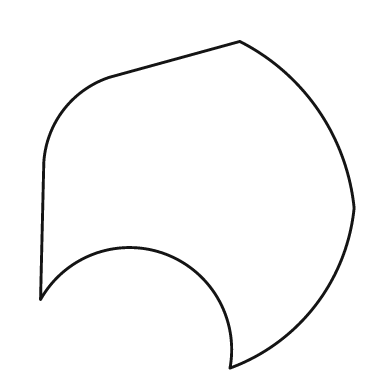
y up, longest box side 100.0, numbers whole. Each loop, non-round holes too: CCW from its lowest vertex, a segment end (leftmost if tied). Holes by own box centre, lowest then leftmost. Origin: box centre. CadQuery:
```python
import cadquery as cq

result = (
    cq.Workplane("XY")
    .moveTo(10.0, -50.0)
    .threePointArc((36.0, -31.0), (48.0, -1.0))
    .threePointArc((37.0, 29.0), (13.0, 50.0))
    .lineTo(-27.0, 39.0)
    .threePointArc((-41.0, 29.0), (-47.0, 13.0))
    .lineTo(-48.0, -29.0)
    .threePointArc((-10.0, -15.0), (10.0, -50.0))
    .close()
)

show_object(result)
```